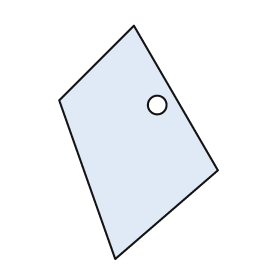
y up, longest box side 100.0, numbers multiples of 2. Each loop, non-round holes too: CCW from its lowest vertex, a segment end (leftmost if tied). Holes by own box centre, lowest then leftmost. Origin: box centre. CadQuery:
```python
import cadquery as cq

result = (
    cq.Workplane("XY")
    .moveTo(-10.0, -50.0)
    .lineTo(34.0, -12.0)
    .lineTo(-2.0, 50.0)
    .lineTo(-34.0, 18.0)
    .close()
    .moveTo(8.0, 16.0)
    .circle(4.0)
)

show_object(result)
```